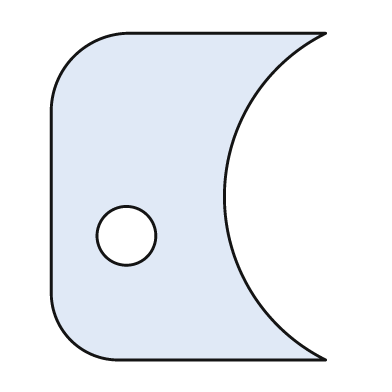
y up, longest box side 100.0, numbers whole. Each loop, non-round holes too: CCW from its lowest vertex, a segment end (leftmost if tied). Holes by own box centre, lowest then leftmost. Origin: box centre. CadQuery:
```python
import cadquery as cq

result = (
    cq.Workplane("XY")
    .moveTo(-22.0, -50.0)
    .lineTo(42.0, -50.0)
    .threePointArc((11.0, 0.0), (42.0, 50.0))
    .lineTo(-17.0, 50.0)
    .threePointArc((-35.0, 43.0), (-42.0, 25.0))
    .lineTo(-42.0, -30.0)
    .threePointArc((-36.0, -44.0), (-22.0, -50.0))
    .close()
    .moveTo(-19.0, -12.0)
    .circle(9.0)
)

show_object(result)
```